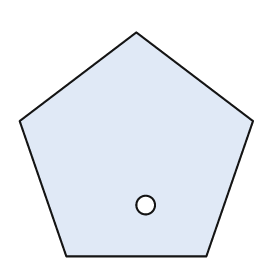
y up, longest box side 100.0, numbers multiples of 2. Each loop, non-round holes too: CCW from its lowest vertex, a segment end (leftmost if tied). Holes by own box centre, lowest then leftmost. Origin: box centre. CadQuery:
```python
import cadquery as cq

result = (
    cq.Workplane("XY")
    .moveTo(-30.0, -48.0)
    .lineTo(30.0, -48.0)
    .lineTo(50.0, 10.0)
    .lineTo(0.0, 48.0)
    .lineTo(-50.0, 10.0)
    .close()
    .moveTo(4.0, -26.0)
    .circle(4.0)
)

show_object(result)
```